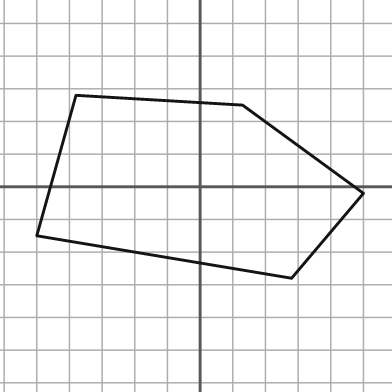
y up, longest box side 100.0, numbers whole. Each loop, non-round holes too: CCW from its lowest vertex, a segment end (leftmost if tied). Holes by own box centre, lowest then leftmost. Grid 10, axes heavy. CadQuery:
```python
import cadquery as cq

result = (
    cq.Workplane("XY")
    .moveTo(28.0, -28.0)
    .lineTo(50.0, -2.0)
    .lineTo(13.0, 25.0)
    .lineTo(-38.0, 28.0)
    .lineTo(-50.0, -15.0)
    .close()
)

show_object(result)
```